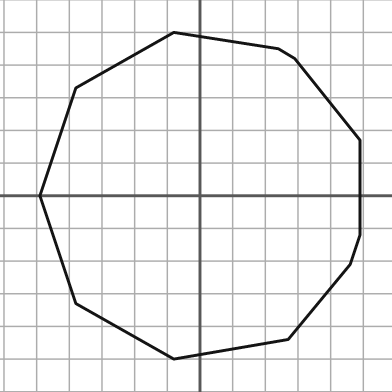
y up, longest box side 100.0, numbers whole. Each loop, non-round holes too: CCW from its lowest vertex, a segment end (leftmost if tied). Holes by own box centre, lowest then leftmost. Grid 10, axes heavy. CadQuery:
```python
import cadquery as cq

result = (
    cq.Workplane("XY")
    .moveTo(-8.0, -50.0)
    .lineTo(27.0, -44.0)
    .lineTo(46.0, -21.0)
    .lineTo(49.0, -12.0)
    .lineTo(49.0, 17.0)
    .lineTo(29.0, 42.0)
    .lineTo(24.0, 45.0)
    .lineTo(-8.0, 50.0)
    .lineTo(-38.0, 33.0)
    .lineTo(-49.0, 0.0)
    .lineTo(-38.0, -33.0)
    .close()
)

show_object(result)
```